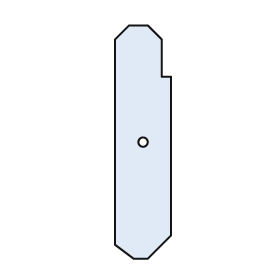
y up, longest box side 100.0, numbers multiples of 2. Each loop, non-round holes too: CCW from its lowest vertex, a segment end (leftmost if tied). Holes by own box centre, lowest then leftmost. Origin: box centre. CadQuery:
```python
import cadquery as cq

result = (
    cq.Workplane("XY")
    .moveTo(-4.0, -50.0)
    .lineTo(2.0, -50.0)
    .lineTo(12.0, -40.0)
    .lineTo(12.0, 28.0)
    .lineTo(8.0, 28.0)
    .lineTo(8.0, 44.0)
    .lineTo(2.0, 50.0)
    .lineTo(-6.0, 50.0)
    .lineTo(-12.0, 44.0)
    .lineTo(-12.0, -44.0)
    .close()
    .moveTo(0.0, 0.0)
    .circle(2.0)
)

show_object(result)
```